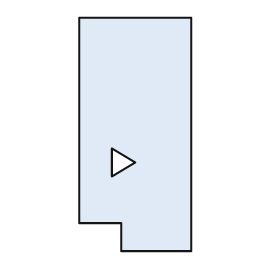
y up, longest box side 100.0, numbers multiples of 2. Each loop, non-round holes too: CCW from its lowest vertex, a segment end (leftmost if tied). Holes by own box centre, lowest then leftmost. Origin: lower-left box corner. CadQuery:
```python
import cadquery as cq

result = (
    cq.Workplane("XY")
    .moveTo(18.0, 0.0)
    .lineTo(48.0, 0.0)
    .lineTo(48.0, 100.0)
    .lineTo(0.0, 100.0)
    .lineTo(0.0, 12.0)
    .lineTo(18.0, 12.0)
    .close()
    .moveTo(14.0, 32.0)
    .lineTo(24.0, 38.0)
    .lineTo(14.0, 44.0)
    .close()
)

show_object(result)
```